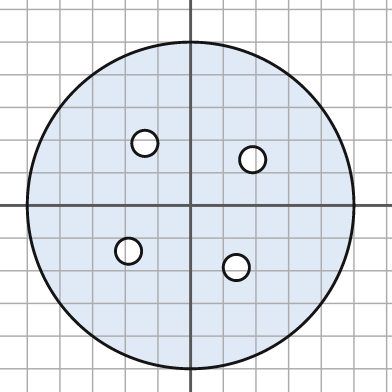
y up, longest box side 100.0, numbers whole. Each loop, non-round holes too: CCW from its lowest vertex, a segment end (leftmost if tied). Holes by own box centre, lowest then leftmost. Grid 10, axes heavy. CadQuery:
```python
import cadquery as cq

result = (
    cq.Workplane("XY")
    .moveTo(0.0, 0.0)
    .circle(50.0)
    .moveTo(14.0, -19.0)
    .circle(4.0)
    .moveTo(-19.0, -14.0)
    .circle(4.0)
    .moveTo(19.0, 14.0)
    .circle(4.0)
    .moveTo(-14.0, 19.0)
    .circle(4.0)
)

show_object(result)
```